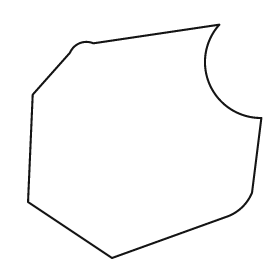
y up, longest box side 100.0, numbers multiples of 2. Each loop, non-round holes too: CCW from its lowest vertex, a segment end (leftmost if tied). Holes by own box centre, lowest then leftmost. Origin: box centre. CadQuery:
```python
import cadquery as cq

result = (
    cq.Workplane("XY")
    .moveTo(-14.0, -50.0)
    .lineTo(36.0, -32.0)
    .threePointArc((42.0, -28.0), (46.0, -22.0))
    .lineTo(50.0, 10.0)
    .threePointArc((28.0, 24.0), (32.0, 50.0))
    .lineTo(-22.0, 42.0)
    .threePointArc((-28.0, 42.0), (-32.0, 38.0))
    .lineTo(-48.0, 20.0)
    .lineTo(-50.0, -26.0)
    .close()
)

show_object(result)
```